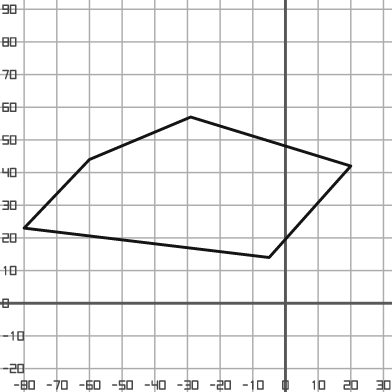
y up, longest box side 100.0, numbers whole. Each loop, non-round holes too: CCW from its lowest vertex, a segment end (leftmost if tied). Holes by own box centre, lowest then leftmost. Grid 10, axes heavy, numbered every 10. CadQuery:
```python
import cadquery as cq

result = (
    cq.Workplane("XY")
    .moveTo(-5.0, 14.0)
    .lineTo(20.0, 42.0)
    .lineTo(-29.0, 57.0)
    .lineTo(-60.0, 44.0)
    .lineTo(-80.0, 23.0)
    .close()
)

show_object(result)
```